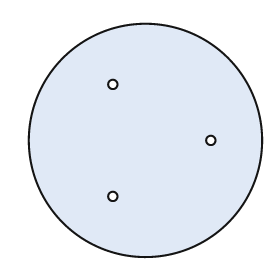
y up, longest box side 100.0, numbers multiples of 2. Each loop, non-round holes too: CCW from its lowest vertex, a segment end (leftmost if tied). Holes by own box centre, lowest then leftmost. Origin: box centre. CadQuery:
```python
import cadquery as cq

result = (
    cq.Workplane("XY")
    .moveTo(0.0, 0.0)
    .circle(50.0)
    .moveTo(-14.0, -24.0)
    .circle(2.0)
    .moveTo(28.0, 0.0)
    .circle(2.0)
    .moveTo(-14.0, 24.0)
    .circle(2.0)
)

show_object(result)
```